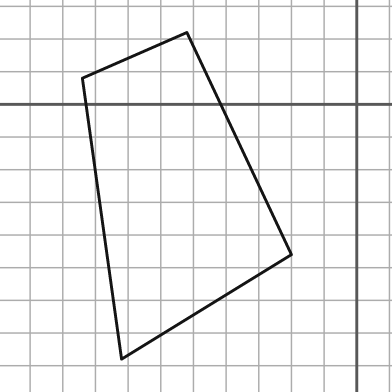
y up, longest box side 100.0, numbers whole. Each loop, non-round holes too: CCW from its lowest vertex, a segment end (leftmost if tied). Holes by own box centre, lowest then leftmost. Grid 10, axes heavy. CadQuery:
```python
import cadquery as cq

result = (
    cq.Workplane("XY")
    .moveTo(-72.0, -78.0)
    .lineTo(-20.0, -46.0)
    .lineTo(-52.0, 22.0)
    .lineTo(-84.0, 8.0)
    .close()
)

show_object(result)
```